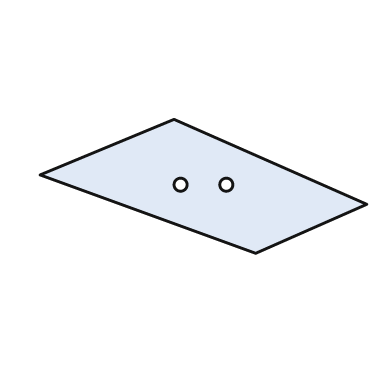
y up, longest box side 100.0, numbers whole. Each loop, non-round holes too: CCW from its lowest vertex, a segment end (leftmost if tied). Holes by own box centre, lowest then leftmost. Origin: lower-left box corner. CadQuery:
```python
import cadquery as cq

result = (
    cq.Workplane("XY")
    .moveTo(66.0, 0.0)
    .lineTo(100.0, 15.0)
    .lineTo(41.0, 41.0)
    .lineTo(0.0, 24.0)
    .close()
    .moveTo(43.0, 21.0)
    .circle(2.0)
    .moveTo(57.0, 21.0)
    .circle(2.0)
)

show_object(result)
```